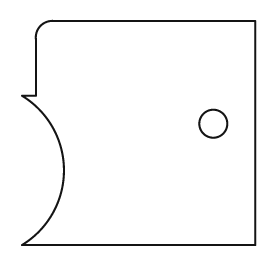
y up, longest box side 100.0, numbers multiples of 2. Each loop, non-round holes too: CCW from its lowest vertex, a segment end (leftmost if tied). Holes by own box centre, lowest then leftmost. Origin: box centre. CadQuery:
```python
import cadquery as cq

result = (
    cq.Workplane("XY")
    .moveTo(-50.0, -48.0)
    .lineTo(50.0, -48.0)
    .lineTo(50.0, 48.0)
    .lineTo(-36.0, 48.0)
    .threePointArc((-42.0, 46.0), (-44.0, 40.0))
    .lineTo(-44.0, 16.0)
    .lineTo(-50.0, 16.0)
    .threePointArc((-32.0, -16.0), (-50.0, -48.0))
    .close()
    .moveTo(32.0, 4.0)
    .circle(6.0)
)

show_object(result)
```